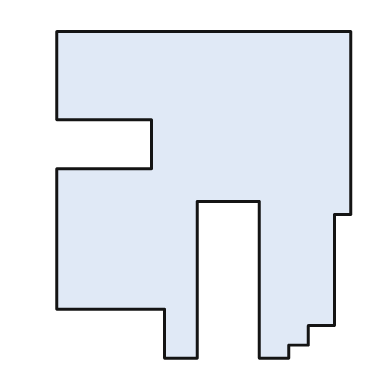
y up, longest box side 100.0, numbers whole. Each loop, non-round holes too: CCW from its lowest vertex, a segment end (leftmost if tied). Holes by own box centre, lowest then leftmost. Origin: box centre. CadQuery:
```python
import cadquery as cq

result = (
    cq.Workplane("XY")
    .moveTo(-12.0, -50.0)
    .lineTo(-2.0, -50.0)
    .lineTo(-2.0, -2.0)
    .lineTo(17.0, -2.0)
    .lineTo(17.0, -50.0)
    .lineTo(26.0, -50.0)
    .lineTo(26.0, -46.0)
    .lineTo(32.0, -46.0)
    .lineTo(32.0, -40.0)
    .lineTo(40.0, -40.0)
    .lineTo(40.0, -6.0)
    .lineTo(45.0, -6.0)
    .lineTo(45.0, 50.0)
    .lineTo(-45.0, 50.0)
    .lineTo(-45.0, 23.0)
    .lineTo(-16.0, 23.0)
    .lineTo(-16.0, 8.0)
    .lineTo(-45.0, 8.0)
    .lineTo(-45.0, -35.0)
    .lineTo(-12.0, -35.0)
    .close()
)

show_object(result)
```